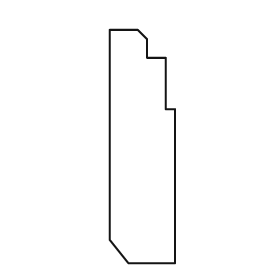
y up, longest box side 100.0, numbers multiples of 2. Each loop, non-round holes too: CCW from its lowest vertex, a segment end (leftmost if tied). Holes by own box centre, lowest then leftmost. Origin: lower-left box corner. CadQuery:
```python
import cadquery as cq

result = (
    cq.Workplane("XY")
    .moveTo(8.0, 0.0)
    .lineTo(28.0, 0.0)
    .lineTo(28.0, 66.0)
    .lineTo(24.0, 66.0)
    .lineTo(24.0, 88.0)
    .lineTo(16.0, 88.0)
    .lineTo(16.0, 96.0)
    .lineTo(12.0, 100.0)
    .lineTo(0.0, 100.0)
    .lineTo(0.0, 10.0)
    .close()
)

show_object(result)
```